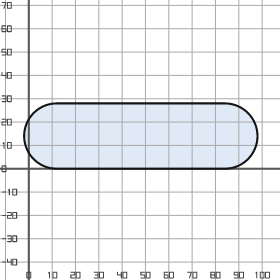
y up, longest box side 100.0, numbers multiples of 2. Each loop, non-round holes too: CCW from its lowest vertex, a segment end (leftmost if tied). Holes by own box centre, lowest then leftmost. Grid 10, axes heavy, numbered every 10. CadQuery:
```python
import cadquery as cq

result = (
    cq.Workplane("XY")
    .moveTo(12.0, 0.0)
    .lineTo(84.0, 0.0)
    .threePointArc((98.0, 14.0), (84.0, 28.0))
    .lineTo(12.0, 28.0)
    .threePointArc((-2.0, 14.0), (12.0, 0.0))
    .close()
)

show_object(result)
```